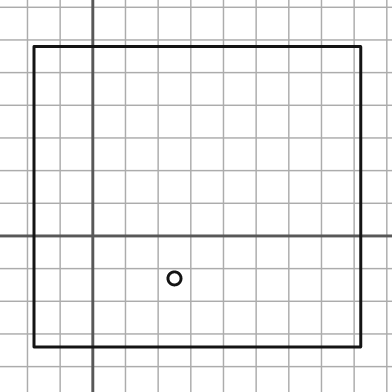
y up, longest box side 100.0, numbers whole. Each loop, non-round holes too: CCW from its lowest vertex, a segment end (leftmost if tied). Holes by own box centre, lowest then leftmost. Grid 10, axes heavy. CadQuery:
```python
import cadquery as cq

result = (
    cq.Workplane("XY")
    .moveTo(-18.0, -34.0)
    .lineTo(82.0, -34.0)
    .lineTo(82.0, 58.0)
    .lineTo(-18.0, 58.0)
    .close()
    .moveTo(25.0, -13.0)
    .circle(2.0)
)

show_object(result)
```